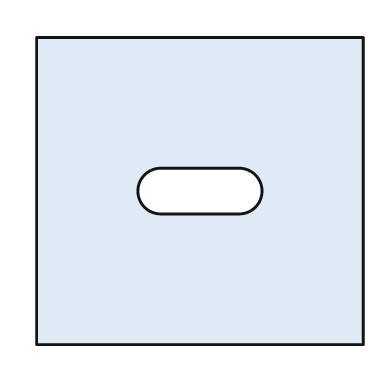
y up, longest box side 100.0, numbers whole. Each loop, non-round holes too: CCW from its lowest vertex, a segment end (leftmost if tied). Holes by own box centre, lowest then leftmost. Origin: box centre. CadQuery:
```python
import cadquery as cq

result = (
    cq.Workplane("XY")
    .moveTo(-50.0, -47.0)
    .lineTo(50.0, -47.0)
    .lineTo(50.0, 47.0)
    .lineTo(-50.0, 47.0)
    .close()
    .moveTo(-12.0, -7.0)
    .lineTo(12.0, -7.0)
    .threePointArc((19.0, 0.0), (12.0, 7.0))
    .lineTo(-12.0, 7.0)
    .threePointArc((-19.0, 0.0), (-12.0, -7.0))
    .close()
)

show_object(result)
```